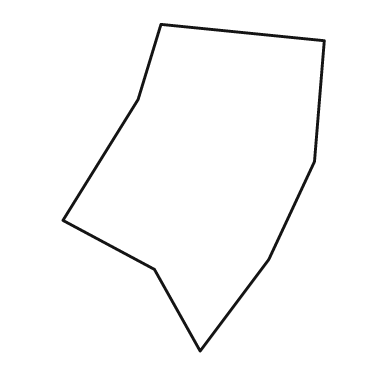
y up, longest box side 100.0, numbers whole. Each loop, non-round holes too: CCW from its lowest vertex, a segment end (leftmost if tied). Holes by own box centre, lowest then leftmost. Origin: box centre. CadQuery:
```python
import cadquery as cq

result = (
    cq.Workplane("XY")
    .moveTo(2.0, -50.0)
    .lineTo(23.0, -22.0)
    .lineTo(37.0, 8.0)
    .lineTo(40.0, 45.0)
    .lineTo(-10.0, 50.0)
    .lineTo(-17.0, 27.0)
    .lineTo(-40.0, -10.0)
    .lineTo(-12.0, -25.0)
    .close()
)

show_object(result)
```